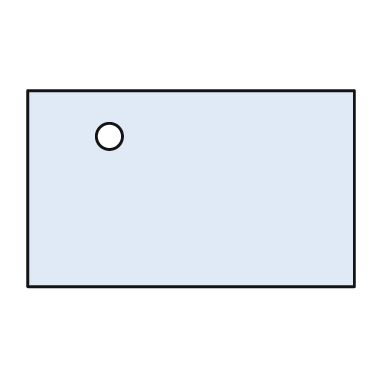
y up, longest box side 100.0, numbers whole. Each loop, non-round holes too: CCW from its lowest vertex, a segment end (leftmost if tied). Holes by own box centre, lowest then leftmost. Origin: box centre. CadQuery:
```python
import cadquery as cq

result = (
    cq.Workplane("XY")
    .moveTo(-50.0, -30.0)
    .lineTo(50.0, -30.0)
    .lineTo(50.0, 30.0)
    .lineTo(-50.0, 30.0)
    .close()
    .moveTo(-25.0, 16.0)
    .circle(4.0)
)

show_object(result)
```